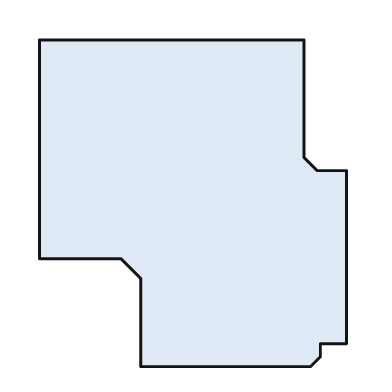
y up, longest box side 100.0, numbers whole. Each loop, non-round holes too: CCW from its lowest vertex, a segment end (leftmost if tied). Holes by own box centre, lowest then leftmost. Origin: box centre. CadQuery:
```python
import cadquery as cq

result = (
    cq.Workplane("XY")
    .moveTo(-16.0, -50.0)
    .lineTo(36.0, -50.0)
    .lineTo(39.0, -47.0)
    .lineTo(39.0, -43.0)
    .lineTo(47.0, -43.0)
    .lineTo(47.0, 10.0)
    .lineTo(38.0, 10.0)
    .lineTo(34.0, 14.0)
    .lineTo(34.0, 50.0)
    .lineTo(-47.0, 50.0)
    .lineTo(-47.0, -17.0)
    .lineTo(-22.0, -17.0)
    .lineTo(-16.0, -23.0)
    .close()
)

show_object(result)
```